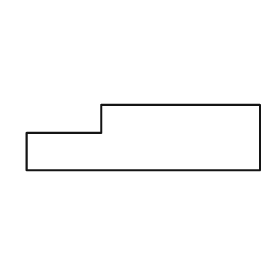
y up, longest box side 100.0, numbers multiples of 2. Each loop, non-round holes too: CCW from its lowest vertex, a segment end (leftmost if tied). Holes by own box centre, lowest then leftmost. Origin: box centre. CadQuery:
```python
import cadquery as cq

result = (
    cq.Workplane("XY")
    .moveTo(-50.0, -14.0)
    .lineTo(50.0, -14.0)
    .lineTo(50.0, 14.0)
    .lineTo(-18.0, 14.0)
    .lineTo(-18.0, 2.0)
    .lineTo(-50.0, 2.0)
    .close()
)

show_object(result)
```